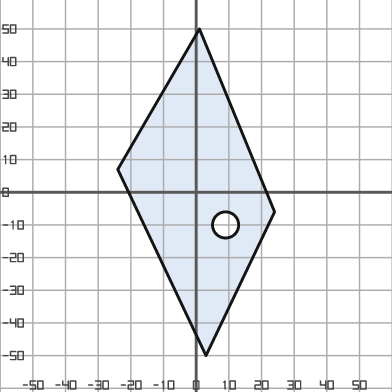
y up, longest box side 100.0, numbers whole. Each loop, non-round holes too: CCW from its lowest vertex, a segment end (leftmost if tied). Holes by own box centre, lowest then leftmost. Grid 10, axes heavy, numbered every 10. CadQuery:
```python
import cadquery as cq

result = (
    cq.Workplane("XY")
    .moveTo(3.0, -50.0)
    .lineTo(24.0, -6.0)
    .lineTo(1.0, 50.0)
    .lineTo(-24.0, 7.0)
    .close()
    .moveTo(9.0, -10.0)
    .circle(4.0)
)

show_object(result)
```